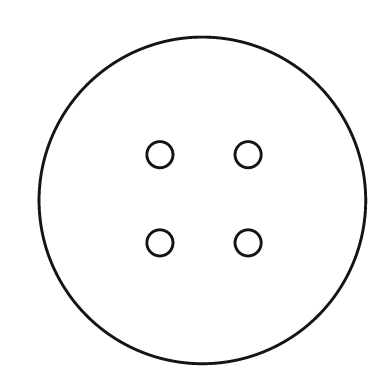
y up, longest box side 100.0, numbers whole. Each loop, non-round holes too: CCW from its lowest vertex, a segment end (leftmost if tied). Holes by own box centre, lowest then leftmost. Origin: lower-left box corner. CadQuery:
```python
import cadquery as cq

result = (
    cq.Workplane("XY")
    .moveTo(50.0, 50.0)
    .circle(50.0)
    .moveTo(37.0, 37.0)
    .circle(4.0)
    .moveTo(64.0, 37.0)
    .circle(4.0)
    .moveTo(37.0, 64.0)
    .circle(4.0)
    .moveTo(64.0, 64.0)
    .circle(4.0)
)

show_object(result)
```